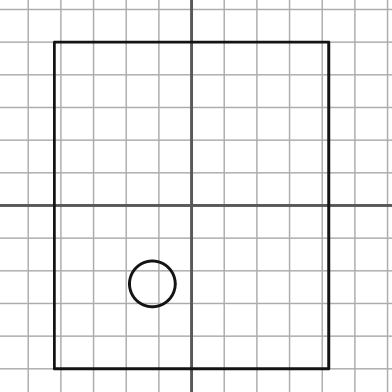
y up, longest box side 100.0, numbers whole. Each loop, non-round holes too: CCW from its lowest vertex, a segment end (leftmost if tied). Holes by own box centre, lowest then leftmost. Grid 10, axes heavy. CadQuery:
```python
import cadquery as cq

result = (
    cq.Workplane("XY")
    .moveTo(-42.0, -50.0)
    .lineTo(42.0, -50.0)
    .lineTo(42.0, 50.0)
    .lineTo(-42.0, 50.0)
    .close()
    .moveTo(-12.0, -24.0)
    .circle(7.0)
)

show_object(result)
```